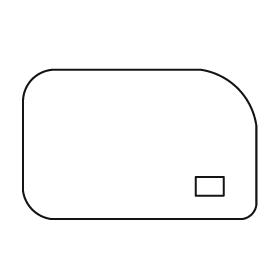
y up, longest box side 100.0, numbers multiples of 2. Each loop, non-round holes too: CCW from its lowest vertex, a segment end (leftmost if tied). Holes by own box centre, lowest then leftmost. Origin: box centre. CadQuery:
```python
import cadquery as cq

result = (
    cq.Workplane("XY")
    .moveTo(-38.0, -32.0)
    .lineTo(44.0, -32.0)
    .threePointArc((48.0, -30.0), (50.0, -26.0))
    .lineTo(50.0, 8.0)
    .threePointArc((42.0, 24.0), (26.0, 32.0))
    .lineTo(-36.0, 32.0)
    .threePointArc((-46.0, 28.0), (-50.0, 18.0))
    .lineTo(-50.0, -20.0)
    .threePointArc((-46.0, -28.0), (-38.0, -32.0))
    .close()
    .moveTo(24.0, -22.0)
    .lineTo(36.0, -22.0)
    .lineTo(36.0, -14.0)
    .lineTo(24.0, -14.0)
    .close()
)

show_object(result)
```